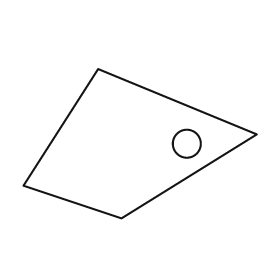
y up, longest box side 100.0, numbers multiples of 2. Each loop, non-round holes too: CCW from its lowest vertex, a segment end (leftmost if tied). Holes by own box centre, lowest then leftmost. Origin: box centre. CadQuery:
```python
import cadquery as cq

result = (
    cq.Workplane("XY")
    .moveTo(-8.0, -32.0)
    .lineTo(50.0, 4.0)
    .lineTo(-18.0, 32.0)
    .lineTo(-50.0, -18.0)
    .close()
    .moveTo(20.0, 0.0)
    .circle(6.0)
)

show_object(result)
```